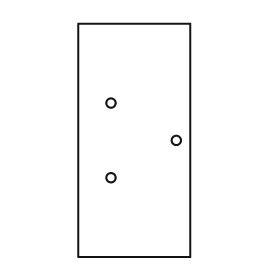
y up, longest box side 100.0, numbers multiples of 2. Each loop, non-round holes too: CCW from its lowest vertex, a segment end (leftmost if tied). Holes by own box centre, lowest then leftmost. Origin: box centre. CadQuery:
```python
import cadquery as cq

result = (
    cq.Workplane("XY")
    .moveTo(-24.0, -50.0)
    .lineTo(24.0, -50.0)
    .lineTo(24.0, 50.0)
    .lineTo(-24.0, 50.0)
    .close()
    .moveTo(-10.0, -16.0)
    .circle(2.0)
    .moveTo(18.0, 0.0)
    .circle(2.0)
    .moveTo(-10.0, 16.0)
    .circle(2.0)
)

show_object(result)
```